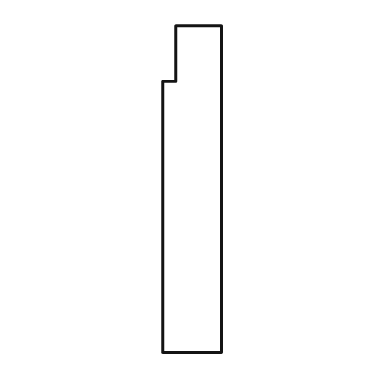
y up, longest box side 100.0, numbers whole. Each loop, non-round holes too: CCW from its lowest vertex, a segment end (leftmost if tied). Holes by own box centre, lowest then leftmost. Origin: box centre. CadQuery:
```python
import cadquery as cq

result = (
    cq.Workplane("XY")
    .moveTo(-9.0, -50.0)
    .lineTo(9.0, -50.0)
    .lineTo(9.0, 50.0)
    .lineTo(-5.0, 50.0)
    .lineTo(-5.0, 33.0)
    .lineTo(-9.0, 33.0)
    .close()
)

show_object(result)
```